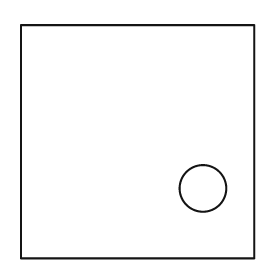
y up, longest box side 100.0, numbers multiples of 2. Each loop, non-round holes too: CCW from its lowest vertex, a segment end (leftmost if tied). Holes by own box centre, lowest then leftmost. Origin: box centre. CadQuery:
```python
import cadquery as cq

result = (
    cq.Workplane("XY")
    .moveTo(-50.0, -50.0)
    .lineTo(50.0, -50.0)
    .lineTo(50.0, 50.0)
    .lineTo(-50.0, 50.0)
    .close()
    .moveTo(28.0, -20.0)
    .circle(10.0)
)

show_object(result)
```